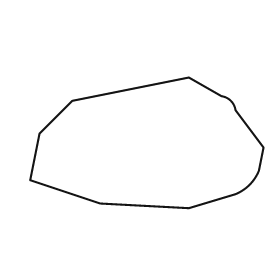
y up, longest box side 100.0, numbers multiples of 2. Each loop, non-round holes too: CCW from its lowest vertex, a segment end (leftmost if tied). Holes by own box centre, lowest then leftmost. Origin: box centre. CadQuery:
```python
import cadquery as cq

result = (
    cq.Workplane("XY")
    .moveTo(18.0, -28.0)
    .lineTo(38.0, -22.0)
    .threePointArc((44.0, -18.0), (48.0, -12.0))
    .lineTo(50.0, -2.0)
    .lineTo(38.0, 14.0)
    .threePointArc((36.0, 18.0), (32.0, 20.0))
    .lineTo(18.0, 28.0)
    .lineTo(-32.0, 18.0)
    .lineTo(-46.0, 4.0)
    .lineTo(-50.0, -16.0)
    .lineTo(-20.0, -26.0)
    .close()
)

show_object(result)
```